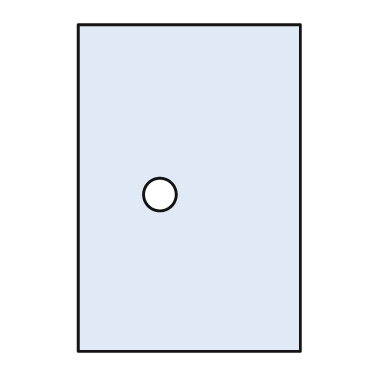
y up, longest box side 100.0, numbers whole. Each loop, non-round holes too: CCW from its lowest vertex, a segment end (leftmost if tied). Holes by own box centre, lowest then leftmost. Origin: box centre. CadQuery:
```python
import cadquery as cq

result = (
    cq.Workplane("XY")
    .moveTo(-34.0, -50.0)
    .lineTo(34.0, -50.0)
    .lineTo(34.0, 50.0)
    .lineTo(-34.0, 50.0)
    .close()
    .moveTo(-9.0, -2.0)
    .circle(5.0)
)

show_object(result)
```